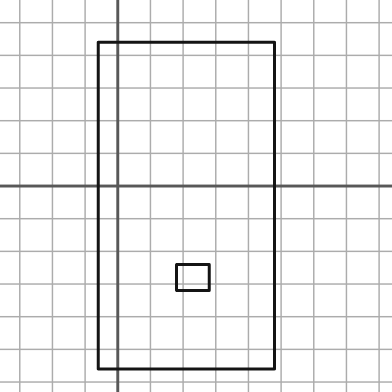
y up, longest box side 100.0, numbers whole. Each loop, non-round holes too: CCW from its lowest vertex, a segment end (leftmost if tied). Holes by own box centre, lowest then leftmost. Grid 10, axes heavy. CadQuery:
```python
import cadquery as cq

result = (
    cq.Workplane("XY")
    .moveTo(-6.0, -56.0)
    .lineTo(48.0, -56.0)
    .lineTo(48.0, 44.0)
    .lineTo(-6.0, 44.0)
    .close()
    .moveTo(18.0, -32.0)
    .lineTo(28.0, -32.0)
    .lineTo(28.0, -24.0)
    .lineTo(18.0, -24.0)
    .close()
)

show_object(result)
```